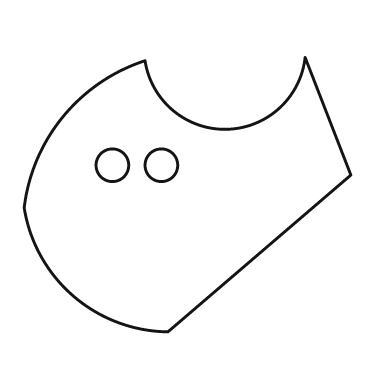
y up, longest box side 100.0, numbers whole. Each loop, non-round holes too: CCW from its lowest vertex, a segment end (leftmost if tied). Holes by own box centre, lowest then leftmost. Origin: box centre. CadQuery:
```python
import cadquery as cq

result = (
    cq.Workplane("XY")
    .moveTo(-6.0, -42.0)
    .lineTo(50.0, 6.0)
    .lineTo(36.0, 42.0)
    .threePointArc((12.0, 20.0), (-13.0, 41.0))
    .threePointArc((-38.0, 24.0), (-50.0, -4.0))
    .threePointArc((-35.0, -31.0), (-6.0, -42.0))
    .close()
    .moveTo(-23.0, 9.0)
    .circle(5.0)
    .moveTo(-8.0, 9.0)
    .circle(5.0)
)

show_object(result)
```